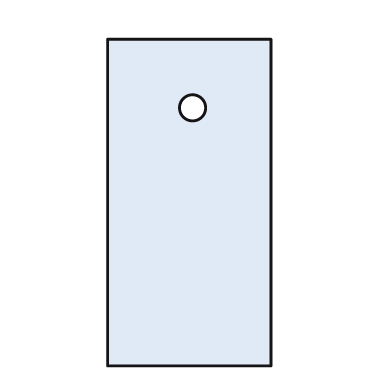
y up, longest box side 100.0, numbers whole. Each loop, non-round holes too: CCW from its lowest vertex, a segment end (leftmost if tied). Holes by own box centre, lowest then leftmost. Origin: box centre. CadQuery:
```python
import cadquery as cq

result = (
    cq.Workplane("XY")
    .moveTo(-25.0, -50.0)
    .lineTo(25.0, -50.0)
    .lineTo(25.0, 50.0)
    .lineTo(-25.0, 50.0)
    .close()
    .moveTo(1.0, 29.0)
    .circle(4.0)
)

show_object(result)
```